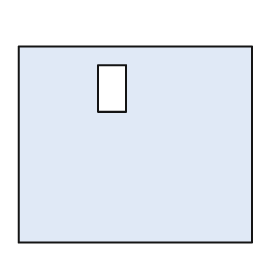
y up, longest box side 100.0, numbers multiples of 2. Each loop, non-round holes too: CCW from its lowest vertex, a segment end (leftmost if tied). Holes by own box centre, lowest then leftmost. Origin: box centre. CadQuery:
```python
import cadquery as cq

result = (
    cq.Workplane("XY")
    .moveTo(-50.0, -42.0)
    .lineTo(50.0, -42.0)
    .lineTo(50.0, 42.0)
    .lineTo(-50.0, 42.0)
    .close()
    .moveTo(-16.0, 14.0)
    .lineTo(-4.0, 14.0)
    .lineTo(-4.0, 34.0)
    .lineTo(-16.0, 34.0)
    .close()
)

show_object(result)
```